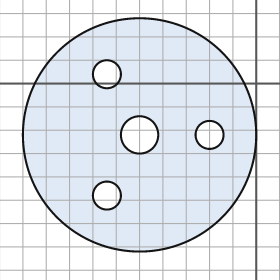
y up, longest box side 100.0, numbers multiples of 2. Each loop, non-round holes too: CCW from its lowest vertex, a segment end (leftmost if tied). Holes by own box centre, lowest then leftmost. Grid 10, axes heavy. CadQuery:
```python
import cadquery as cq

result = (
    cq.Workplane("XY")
    .moveTo(-50.0, -22.0)
    .circle(50.0)
    .moveTo(-64.0, -48.0)
    .circle(6.0)
    .moveTo(-50.0, -22.0)
    .circle(8.0)
    .moveTo(-20.0, -22.0)
    .circle(6.0)
    .moveTo(-64.0, 4.0)
    .circle(6.0)
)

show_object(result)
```